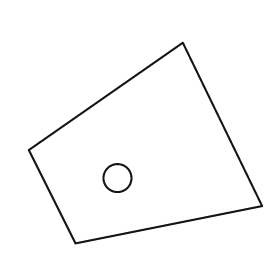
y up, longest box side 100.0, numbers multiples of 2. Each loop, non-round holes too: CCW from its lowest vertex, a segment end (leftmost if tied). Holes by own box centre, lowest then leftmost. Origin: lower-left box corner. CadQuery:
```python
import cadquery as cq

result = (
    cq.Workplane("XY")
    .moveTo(20.0, 0.0)
    .lineTo(100.0, 16.0)
    .lineTo(66.0, 86.0)
    .lineTo(0.0, 40.0)
    .close()
    .moveTo(38.0, 28.0)
    .circle(6.0)
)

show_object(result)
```